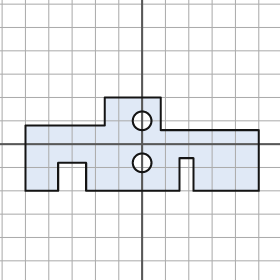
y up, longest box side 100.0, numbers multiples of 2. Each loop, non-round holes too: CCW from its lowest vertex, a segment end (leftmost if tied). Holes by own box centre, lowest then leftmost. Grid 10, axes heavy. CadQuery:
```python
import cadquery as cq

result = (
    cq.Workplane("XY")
    .moveTo(-50.0, -20.0)
    .lineTo(-36.0, -20.0)
    .lineTo(-36.0, -8.0)
    .lineTo(-24.0, -8.0)
    .lineTo(-24.0, -20.0)
    .lineTo(16.0, -20.0)
    .lineTo(16.0, -6.0)
    .lineTo(22.0, -6.0)
    .lineTo(22.0, -20.0)
    .lineTo(50.0, -20.0)
    .lineTo(50.0, 6.0)
    .lineTo(8.0, 6.0)
    .lineTo(8.0, 20.0)
    .lineTo(-16.0, 20.0)
    .lineTo(-16.0, 8.0)
    .lineTo(-50.0, 8.0)
    .close()
    .moveTo(0.0, -8.0)
    .circle(4.0)
    .moveTo(0.0, 10.0)
    .circle(4.0)
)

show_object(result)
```